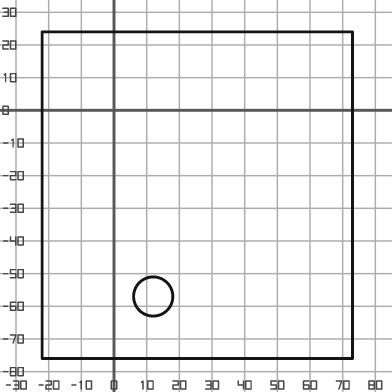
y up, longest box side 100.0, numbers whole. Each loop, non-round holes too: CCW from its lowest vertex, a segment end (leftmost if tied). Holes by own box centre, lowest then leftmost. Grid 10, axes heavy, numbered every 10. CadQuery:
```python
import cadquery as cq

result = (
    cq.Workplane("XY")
    .moveTo(-22.0, -76.0)
    .lineTo(73.0, -76.0)
    .lineTo(73.0, 24.0)
    .lineTo(-22.0, 24.0)
    .close()
    .moveTo(12.0, -57.0)
    .circle(6.0)
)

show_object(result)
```